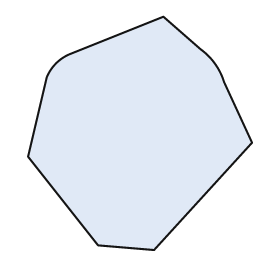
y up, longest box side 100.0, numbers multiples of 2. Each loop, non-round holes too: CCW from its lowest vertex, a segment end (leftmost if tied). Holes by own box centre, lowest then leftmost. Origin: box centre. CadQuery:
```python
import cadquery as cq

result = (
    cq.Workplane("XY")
    .moveTo(6.0, -50.0)
    .lineTo(48.0, -4.0)
    .lineTo(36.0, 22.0)
    .threePointArc((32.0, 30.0), (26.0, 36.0))
    .lineTo(10.0, 50.0)
    .lineTo(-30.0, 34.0)
    .threePointArc((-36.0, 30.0), (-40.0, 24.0))
    .lineTo(-48.0, -10.0)
    .lineTo(-18.0, -48.0)
    .close()
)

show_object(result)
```